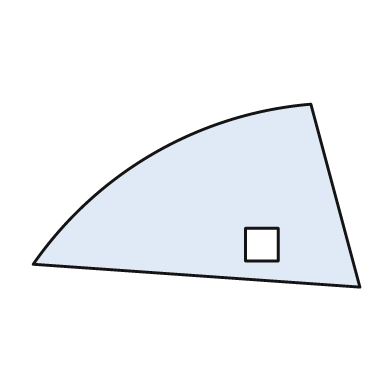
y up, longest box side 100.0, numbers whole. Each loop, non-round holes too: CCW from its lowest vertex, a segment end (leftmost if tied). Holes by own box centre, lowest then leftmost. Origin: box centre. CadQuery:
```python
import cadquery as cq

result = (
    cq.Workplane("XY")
    .moveTo(50.0, -28.0)
    .lineTo(35.0, 28.0)
    .threePointArc((-13.0, 13.0), (-50.0, -21.0))
    .close()
    .moveTo(15.0, -20.0)
    .lineTo(25.0, -20.0)
    .lineTo(25.0, -10.0)
    .lineTo(15.0, -10.0)
    .close()
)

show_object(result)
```